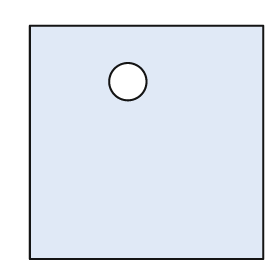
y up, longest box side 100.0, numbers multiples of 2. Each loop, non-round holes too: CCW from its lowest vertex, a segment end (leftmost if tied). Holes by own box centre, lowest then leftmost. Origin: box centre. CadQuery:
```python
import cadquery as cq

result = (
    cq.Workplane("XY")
    .moveTo(-50.0, -50.0)
    .lineTo(50.0, -50.0)
    .lineTo(50.0, 50.0)
    .lineTo(-50.0, 50.0)
    .close()
    .moveTo(-8.0, 26.0)
    .circle(8.0)
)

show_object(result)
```